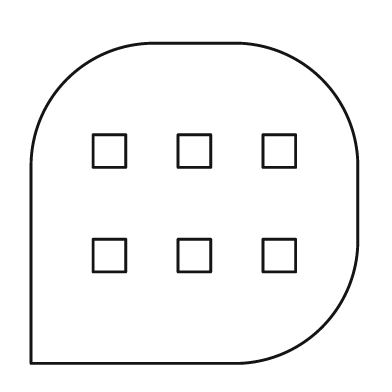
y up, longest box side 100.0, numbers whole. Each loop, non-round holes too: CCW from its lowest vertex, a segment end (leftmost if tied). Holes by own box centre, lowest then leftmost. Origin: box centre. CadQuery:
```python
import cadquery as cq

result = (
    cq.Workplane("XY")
    .moveTo(-50.0, -49.0)
    .lineTo(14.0, -49.0)
    .threePointArc((39.0, -38.0), (50.0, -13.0))
    .lineTo(50.0, 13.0)
    .threePointArc((39.0, 38.0), (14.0, 49.0))
    .lineTo(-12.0, 49.0)
    .threePointArc((-39.0, 38.0), (-50.0, 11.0))
    .close()
    .moveTo(-31.0, -21.0)
    .lineTo(-21.0, -21.0)
    .lineTo(-21.0, -11.0)
    .lineTo(-31.0, -11.0)
    .close()
    .moveTo(-5.0, -21.0)
    .lineTo(5.0, -21.0)
    .lineTo(5.0, -11.0)
    .lineTo(-5.0, -11.0)
    .close()
    .moveTo(21.0, -21.0)
    .lineTo(31.0, -21.0)
    .lineTo(31.0, -11.0)
    .lineTo(21.0, -11.0)
    .close()
    .moveTo(-31.0, 11.0)
    .lineTo(-21.0, 11.0)
    .lineTo(-21.0, 21.0)
    .lineTo(-31.0, 21.0)
    .close()
    .moveTo(-5.0, 11.0)
    .lineTo(5.0, 11.0)
    .lineTo(5.0, 21.0)
    .lineTo(-5.0, 21.0)
    .close()
    .moveTo(21.0, 11.0)
    .lineTo(31.0, 11.0)
    .lineTo(31.0, 21.0)
    .lineTo(21.0, 21.0)
    .close()
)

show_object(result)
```